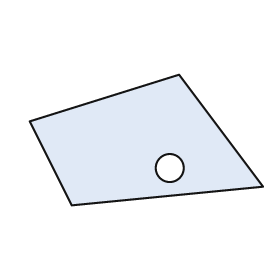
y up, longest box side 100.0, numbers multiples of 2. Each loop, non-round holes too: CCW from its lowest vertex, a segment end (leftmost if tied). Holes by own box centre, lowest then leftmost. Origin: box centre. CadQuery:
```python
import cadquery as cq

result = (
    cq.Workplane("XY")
    .moveTo(-32.0, -28.0)
    .lineTo(50.0, -20.0)
    .lineTo(14.0, 28.0)
    .lineTo(-50.0, 8.0)
    .close()
    .moveTo(10.0, -12.0)
    .circle(6.0)
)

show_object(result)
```